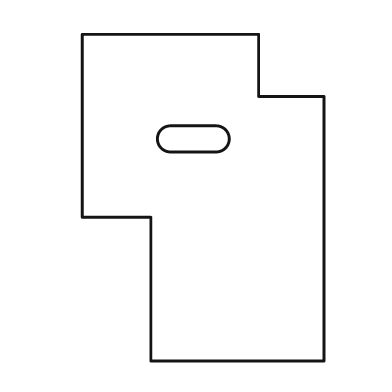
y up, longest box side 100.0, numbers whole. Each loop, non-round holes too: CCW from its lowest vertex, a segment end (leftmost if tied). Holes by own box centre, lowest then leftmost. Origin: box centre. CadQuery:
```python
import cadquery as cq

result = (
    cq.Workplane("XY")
    .moveTo(-16.0, -50.0)
    .lineTo(37.0, -50.0)
    .lineTo(37.0, 31.0)
    .lineTo(17.0, 31.0)
    .lineTo(17.0, 50.0)
    .lineTo(-37.0, 50.0)
    .lineTo(-37.0, -6.0)
    .lineTo(-16.0, -6.0)
    .close()
    .moveTo(-10.0, 14.0)
    .lineTo(4.0, 14.0)
    .threePointArc((8.0, 18.0), (4.0, 22.0))
    .lineTo(-10.0, 22.0)
    .threePointArc((-14.0, 18.0), (-10.0, 14.0))
    .close()
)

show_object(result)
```